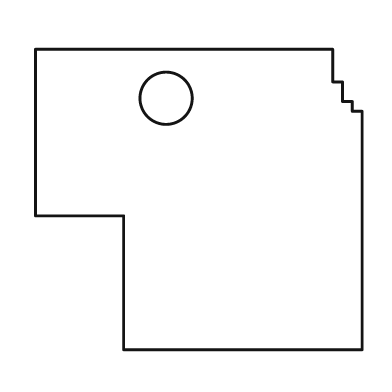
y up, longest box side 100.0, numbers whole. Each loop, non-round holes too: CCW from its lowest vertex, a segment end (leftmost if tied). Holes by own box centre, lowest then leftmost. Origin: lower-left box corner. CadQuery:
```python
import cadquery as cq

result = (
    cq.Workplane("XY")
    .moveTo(27.0, 0.0)
    .lineTo(100.0, 0.0)
    .lineTo(100.0, 73.0)
    .lineTo(97.0, 73.0)
    .lineTo(97.0, 76.0)
    .lineTo(94.0, 76.0)
    .lineTo(94.0, 82.0)
    .lineTo(91.0, 82.0)
    .lineTo(91.0, 92.0)
    .lineTo(0.0, 92.0)
    .lineTo(0.0, 41.0)
    .lineTo(27.0, 41.0)
    .close()
    .moveTo(40.0, 77.0)
    .circle(8.0)
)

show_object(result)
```